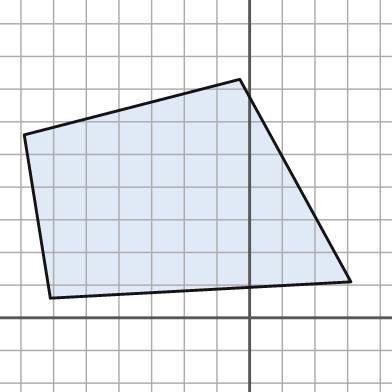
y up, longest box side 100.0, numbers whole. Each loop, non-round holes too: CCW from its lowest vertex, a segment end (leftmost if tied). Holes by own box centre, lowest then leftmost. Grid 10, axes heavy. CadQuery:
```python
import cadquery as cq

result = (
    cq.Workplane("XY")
    .moveTo(-61.0, 6.0)
    .lineTo(31.0, 11.0)
    .lineTo(-3.0, 73.0)
    .lineTo(-69.0, 56.0)
    .close()
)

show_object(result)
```